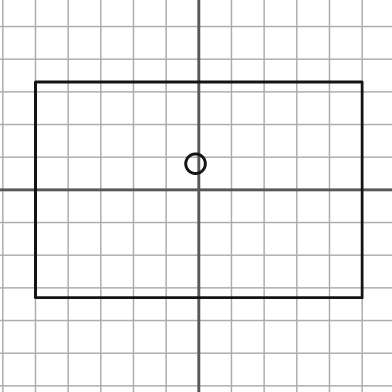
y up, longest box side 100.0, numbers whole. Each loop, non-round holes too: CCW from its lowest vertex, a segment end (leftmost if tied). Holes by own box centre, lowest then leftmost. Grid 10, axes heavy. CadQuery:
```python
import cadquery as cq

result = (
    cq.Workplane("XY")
    .moveTo(-50.0, -33.0)
    .lineTo(50.0, -33.0)
    .lineTo(50.0, 33.0)
    .lineTo(-50.0, 33.0)
    .close()
    .moveTo(-1.0, 8.0)
    .circle(3.0)
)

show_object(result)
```